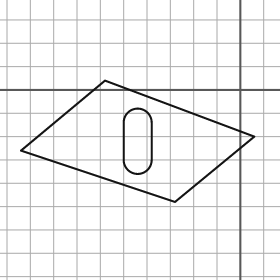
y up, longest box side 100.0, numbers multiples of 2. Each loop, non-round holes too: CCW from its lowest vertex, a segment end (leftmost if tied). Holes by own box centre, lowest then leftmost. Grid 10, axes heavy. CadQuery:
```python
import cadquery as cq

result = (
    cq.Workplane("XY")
    .moveTo(-28.0, -48.0)
    .lineTo(6.0, -20.0)
    .lineTo(-58.0, 4.0)
    .lineTo(-94.0, -26.0)
    .close()
    .moveTo(-50.0, -30.0)
    .threePointArc((-44.0, -36.0), (-38.0, -30.0))
    .lineTo(-38.0, -14.0)
    .threePointArc((-44.0, -8.0), (-50.0, -14.0))
    .close()
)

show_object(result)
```